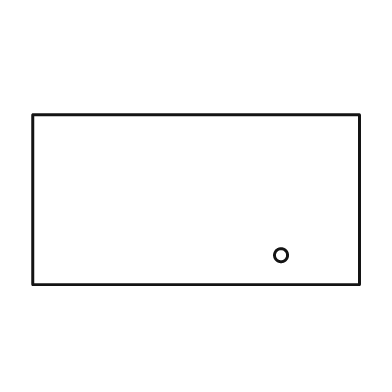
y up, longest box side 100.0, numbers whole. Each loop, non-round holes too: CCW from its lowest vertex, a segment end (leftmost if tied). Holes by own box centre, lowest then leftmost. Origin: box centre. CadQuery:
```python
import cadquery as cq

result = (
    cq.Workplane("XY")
    .moveTo(-50.0, -26.0)
    .lineTo(50.0, -26.0)
    .lineTo(50.0, 26.0)
    .lineTo(-50.0, 26.0)
    .close()
    .moveTo(26.0, -17.0)
    .circle(2.0)
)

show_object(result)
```